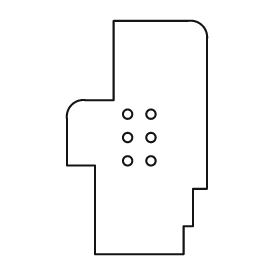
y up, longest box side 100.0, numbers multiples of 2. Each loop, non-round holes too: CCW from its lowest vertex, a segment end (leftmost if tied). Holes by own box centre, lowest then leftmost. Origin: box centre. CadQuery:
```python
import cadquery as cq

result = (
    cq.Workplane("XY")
    .moveTo(-18.0, -50.0)
    .lineTo(20.0, -50.0)
    .lineTo(20.0, -38.0)
    .lineTo(24.0, -38.0)
    .lineTo(24.0, -22.0)
    .lineTo(30.0, -22.0)
    .lineTo(30.0, 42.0)
    .threePointArc((28.0, 48.0), (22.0, 50.0))
    .lineTo(-10.0, 50.0)
    .lineTo(-10.0, 16.0)
    .lineTo(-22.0, 16.0)
    .threePointArc((-28.0, 14.0), (-30.0, 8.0))
    .lineTo(-30.0, -12.0)
    .lineTo(-18.0, -12.0)
    .close()
    .moveTo(-4.0, -10.0)
    .circle(2.0)
    .moveTo(6.0, -10.0)
    .circle(2.0)
    .moveTo(-4.0, 0.0)
    .circle(2.0)
    .moveTo(6.0, 0.0)
    .circle(2.0)
    .moveTo(-4.0, 10.0)
    .circle(2.0)
    .moveTo(6.0, 10.0)
    .circle(2.0)
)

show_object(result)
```